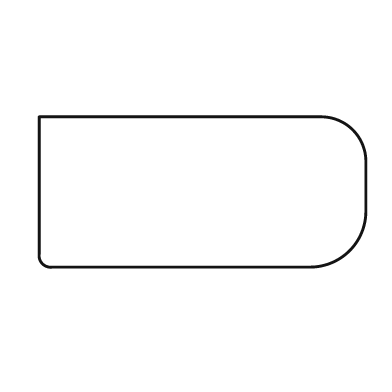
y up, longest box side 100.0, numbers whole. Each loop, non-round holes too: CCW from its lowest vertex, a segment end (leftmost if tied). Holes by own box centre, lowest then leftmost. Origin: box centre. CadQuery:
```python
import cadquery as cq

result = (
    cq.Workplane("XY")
    .moveTo(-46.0, -23.0)
    .lineTo(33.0, -23.0)
    .threePointArc((45.0, -18.0), (50.0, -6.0))
    .lineTo(50.0, 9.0)
    .threePointArc((46.0, 19.0), (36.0, 23.0))
    .lineTo(-50.0, 23.0)
    .lineTo(-50.0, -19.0)
    .threePointArc((-49.0, -22.0), (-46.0, -23.0))
    .close()
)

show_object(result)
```